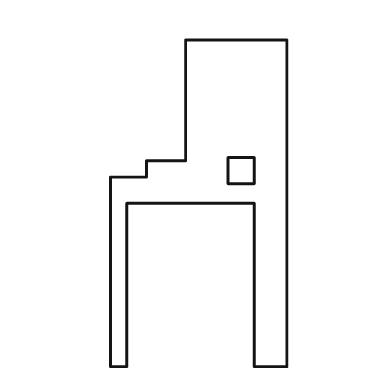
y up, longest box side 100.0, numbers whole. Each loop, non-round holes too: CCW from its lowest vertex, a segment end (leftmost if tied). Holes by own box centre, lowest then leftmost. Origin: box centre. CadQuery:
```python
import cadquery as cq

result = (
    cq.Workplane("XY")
    .moveTo(-27.0, -50.0)
    .lineTo(-22.0, -50.0)
    .lineTo(-22.0, 0.0)
    .lineTo(17.0, 0.0)
    .lineTo(17.0, -50.0)
    .lineTo(27.0, -50.0)
    .lineTo(27.0, 50.0)
    .lineTo(-4.0, 50.0)
    .lineTo(-4.0, 13.0)
    .lineTo(-16.0, 13.0)
    .lineTo(-16.0, 8.0)
    .lineTo(-27.0, 8.0)
    .close()
    .moveTo(9.0, 6.0)
    .lineTo(17.0, 6.0)
    .lineTo(17.0, 14.0)
    .lineTo(9.0, 14.0)
    .close()
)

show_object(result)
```